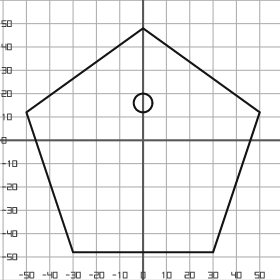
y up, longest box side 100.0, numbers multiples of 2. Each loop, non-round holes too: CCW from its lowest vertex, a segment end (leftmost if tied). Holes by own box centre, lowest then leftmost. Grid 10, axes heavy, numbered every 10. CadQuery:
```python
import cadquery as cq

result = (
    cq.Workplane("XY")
    .moveTo(-30.0, -48.0)
    .lineTo(30.0, -48.0)
    .lineTo(50.0, 12.0)
    .lineTo(0.0, 48.0)
    .lineTo(-50.0, 12.0)
    .close()
    .moveTo(0.0, 16.0)
    .circle(4.0)
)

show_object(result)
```